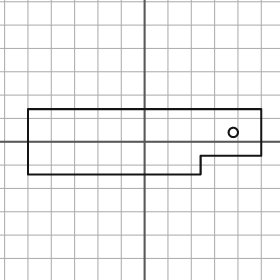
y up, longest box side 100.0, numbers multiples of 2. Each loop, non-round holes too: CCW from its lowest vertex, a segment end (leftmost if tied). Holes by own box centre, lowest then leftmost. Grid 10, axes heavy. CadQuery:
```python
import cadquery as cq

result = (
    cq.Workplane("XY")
    .moveTo(-50.0, -14.0)
    .lineTo(24.0, -14.0)
    .lineTo(24.0, -6.0)
    .lineTo(50.0, -6.0)
    .lineTo(50.0, 14.0)
    .lineTo(-50.0, 14.0)
    .close()
    .moveTo(38.0, 4.0)
    .circle(2.0)
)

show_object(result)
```